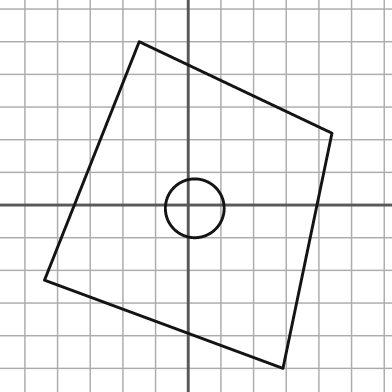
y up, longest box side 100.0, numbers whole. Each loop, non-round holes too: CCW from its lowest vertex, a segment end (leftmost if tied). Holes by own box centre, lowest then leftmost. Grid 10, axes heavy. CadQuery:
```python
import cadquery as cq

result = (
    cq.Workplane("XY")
    .moveTo(29.0, -50.0)
    .lineTo(44.0, 22.0)
    .lineTo(-15.0, 50.0)
    .lineTo(-44.0, -23.0)
    .close()
    .moveTo(2.0, -1.0)
    .circle(9.0)
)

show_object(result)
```